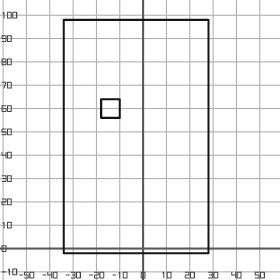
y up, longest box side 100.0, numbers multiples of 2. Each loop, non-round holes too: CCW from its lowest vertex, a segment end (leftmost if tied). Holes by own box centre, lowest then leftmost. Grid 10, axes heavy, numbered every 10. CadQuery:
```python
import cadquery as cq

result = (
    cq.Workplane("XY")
    .moveTo(-34.0, -2.0)
    .lineTo(28.0, -2.0)
    .lineTo(28.0, 98.0)
    .lineTo(-34.0, 98.0)
    .close()
    .moveTo(-18.0, 56.0)
    .lineTo(-10.0, 56.0)
    .lineTo(-10.0, 64.0)
    .lineTo(-18.0, 64.0)
    .close()
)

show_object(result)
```